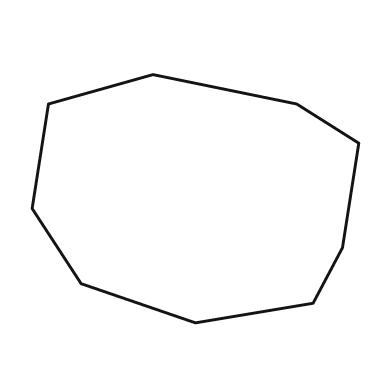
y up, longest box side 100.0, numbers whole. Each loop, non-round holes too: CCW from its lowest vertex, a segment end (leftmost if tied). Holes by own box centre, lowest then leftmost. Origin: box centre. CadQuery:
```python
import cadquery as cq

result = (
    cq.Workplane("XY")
    .moveTo(0.0, -38.0)
    .lineTo(36.0, -32.0)
    .lineTo(45.0, -15.0)
    .lineTo(50.0, 17.0)
    .lineTo(31.0, 29.0)
    .lineTo(-13.0, 38.0)
    .lineTo(-45.0, 29.0)
    .lineTo(-50.0, -3.0)
    .lineTo(-35.0, -26.0)
    .close()
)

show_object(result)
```